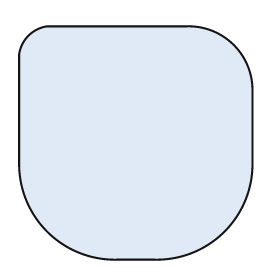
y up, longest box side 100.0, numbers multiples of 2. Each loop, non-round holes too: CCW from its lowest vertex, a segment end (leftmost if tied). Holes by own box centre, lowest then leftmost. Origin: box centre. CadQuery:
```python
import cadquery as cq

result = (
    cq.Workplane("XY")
    .moveTo(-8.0, -50.0)
    .lineTo(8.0, -50.0)
    .threePointArc((38.0, -38.0), (50.0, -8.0))
    .lineTo(50.0, 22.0)
    .threePointArc((42.0, 42.0), (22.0, 50.0))
    .lineTo(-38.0, 50.0)
    .threePointArc((-46.0, 46.0), (-50.0, 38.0))
    .lineTo(-50.0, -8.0)
    .threePointArc((-38.0, -38.0), (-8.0, -50.0))
    .close()
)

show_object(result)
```